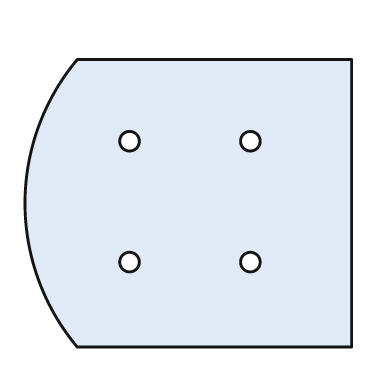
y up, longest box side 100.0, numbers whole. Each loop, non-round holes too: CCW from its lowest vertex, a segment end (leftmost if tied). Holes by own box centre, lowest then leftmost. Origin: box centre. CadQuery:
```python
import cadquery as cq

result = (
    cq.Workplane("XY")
    .moveTo(-34.0, -44.0)
    .lineTo(50.0, -44.0)
    .lineTo(50.0, 44.0)
    .lineTo(-34.0, 44.0)
    .threePointArc((-50.0, 0.0), (-34.0, -44.0))
    .close()
    .moveTo(-18.0, -18.0)
    .circle(3.0)
    .moveTo(19.0, -18.0)
    .circle(3.0)
    .moveTo(-18.0, 19.0)
    .circle(3.0)
    .moveTo(19.0, 19.0)
    .circle(3.0)
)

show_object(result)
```